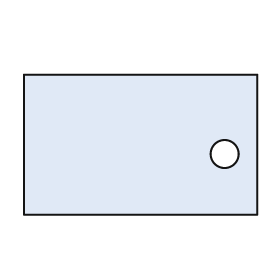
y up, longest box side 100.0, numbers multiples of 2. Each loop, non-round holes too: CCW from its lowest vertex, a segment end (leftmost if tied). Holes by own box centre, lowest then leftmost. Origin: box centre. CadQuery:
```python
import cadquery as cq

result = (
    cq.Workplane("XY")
    .moveTo(-50.0, -30.0)
    .lineTo(50.0, -30.0)
    .lineTo(50.0, 30.0)
    .lineTo(-50.0, 30.0)
    .close()
    .moveTo(36.0, -4.0)
    .circle(6.0)
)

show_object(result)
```